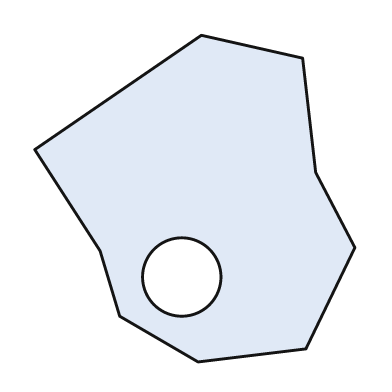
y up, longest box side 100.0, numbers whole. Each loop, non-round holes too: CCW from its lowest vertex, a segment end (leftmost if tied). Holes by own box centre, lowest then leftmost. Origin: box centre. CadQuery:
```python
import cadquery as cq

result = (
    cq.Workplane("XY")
    .moveTo(1.0, -50.0)
    .lineTo(34.0, -46.0)
    .lineTo(49.0, -15.0)
    .lineTo(37.0, 8.0)
    .lineTo(33.0, 43.0)
    .lineTo(2.0, 50.0)
    .lineTo(-49.0, 15.0)
    .lineTo(-29.0, -16.0)
    .lineTo(-23.0, -36.0)
    .close()
    .moveTo(-4.0, -24.0)
    .circle(12.0)
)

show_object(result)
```